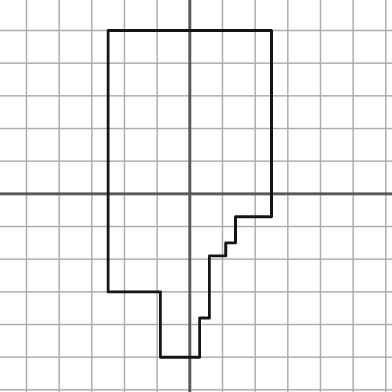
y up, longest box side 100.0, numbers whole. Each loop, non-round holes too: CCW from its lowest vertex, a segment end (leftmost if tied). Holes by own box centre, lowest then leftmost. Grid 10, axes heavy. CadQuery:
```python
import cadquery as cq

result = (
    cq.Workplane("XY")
    .moveTo(-9.0, -50.0)
    .lineTo(3.0, -50.0)
    .lineTo(3.0, -38.0)
    .lineTo(6.0, -38.0)
    .lineTo(6.0, -19.0)
    .lineTo(11.0, -19.0)
    .lineTo(11.0, -15.0)
    .lineTo(14.0, -15.0)
    .lineTo(14.0, -7.0)
    .lineTo(25.0, -7.0)
    .lineTo(25.0, 50.0)
    .lineTo(-25.0, 50.0)
    .lineTo(-25.0, -30.0)
    .lineTo(-9.0, -30.0)
    .close()
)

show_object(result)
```